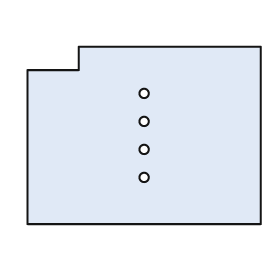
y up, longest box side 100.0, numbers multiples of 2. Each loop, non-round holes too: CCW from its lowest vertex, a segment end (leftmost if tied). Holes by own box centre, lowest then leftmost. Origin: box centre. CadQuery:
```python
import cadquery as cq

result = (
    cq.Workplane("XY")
    .moveTo(-50.0, -38.0)
    .lineTo(50.0, -38.0)
    .lineTo(50.0, 38.0)
    .lineTo(-28.0, 38.0)
    .lineTo(-28.0, 28.0)
    .lineTo(-50.0, 28.0)
    .close()
    .moveTo(0.0, -18.0)
    .circle(2.0)
    .moveTo(0.0, -6.0)
    .circle(2.0)
    .moveTo(0.0, 6.0)
    .circle(2.0)
    .moveTo(0.0, 18.0)
    .circle(2.0)
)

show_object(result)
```